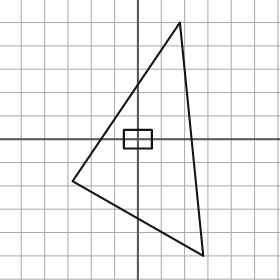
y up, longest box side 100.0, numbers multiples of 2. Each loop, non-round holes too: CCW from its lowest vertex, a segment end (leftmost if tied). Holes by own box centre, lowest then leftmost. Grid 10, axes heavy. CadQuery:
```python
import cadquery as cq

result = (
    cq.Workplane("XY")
    .moveTo(28.0, -50.0)
    .lineTo(18.0, 50.0)
    .lineTo(-28.0, -18.0)
    .close()
    .moveTo(-6.0, -4.0)
    .lineTo(6.0, -4.0)
    .lineTo(6.0, 4.0)
    .lineTo(-6.0, 4.0)
    .close()
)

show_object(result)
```